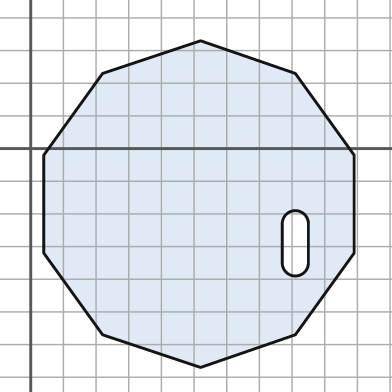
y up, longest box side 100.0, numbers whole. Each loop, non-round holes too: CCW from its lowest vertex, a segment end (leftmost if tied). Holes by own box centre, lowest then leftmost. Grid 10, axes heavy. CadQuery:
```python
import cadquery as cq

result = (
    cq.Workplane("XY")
    .moveTo(52.0, -67.0)
    .lineTo(81.0, -57.0)
    .lineTo(99.0, -32.0)
    .lineTo(99.0, -2.0)
    .lineTo(81.0, 23.0)
    .lineTo(52.0, 33.0)
    .lineTo(22.0, 23.0)
    .lineTo(4.0, -2.0)
    .lineTo(4.0, -32.0)
    .lineTo(22.0, -57.0)
    .close()
    .moveTo(77.0, -35.0)
    .threePointArc((81.0, -39.0), (85.0, -35.0))
    .lineTo(85.0, -23.0)
    .threePointArc((81.0, -19.0), (77.0, -23.0))
    .close()
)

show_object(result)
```